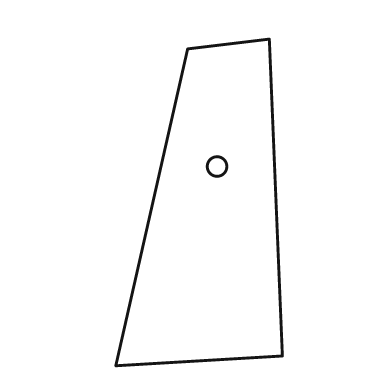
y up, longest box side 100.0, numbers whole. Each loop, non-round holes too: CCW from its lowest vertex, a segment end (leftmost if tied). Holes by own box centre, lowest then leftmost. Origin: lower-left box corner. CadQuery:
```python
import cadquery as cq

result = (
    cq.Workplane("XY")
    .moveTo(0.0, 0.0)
    .lineTo(51.0, 3.0)
    .lineTo(47.0, 100.0)
    .lineTo(22.0, 97.0)
    .close()
    .moveTo(31.0, 61.0)
    .circle(3.0)
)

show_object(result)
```